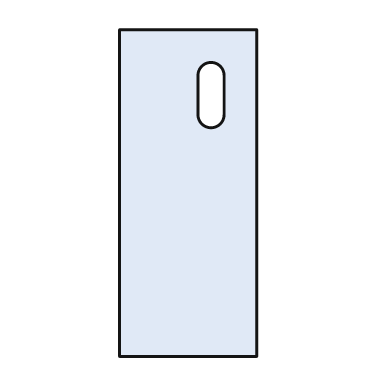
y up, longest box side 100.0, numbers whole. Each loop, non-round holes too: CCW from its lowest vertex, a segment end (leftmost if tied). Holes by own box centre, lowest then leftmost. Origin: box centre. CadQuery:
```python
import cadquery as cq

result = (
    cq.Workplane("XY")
    .moveTo(-21.0, -50.0)
    .lineTo(21.0, -50.0)
    .lineTo(21.0, 50.0)
    .lineTo(-21.0, 50.0)
    .close()
    .moveTo(3.0, 24.0)
    .threePointArc((7.0, 20.0), (11.0, 24.0))
    .lineTo(11.0, 36.0)
    .threePointArc((7.0, 40.0), (3.0, 36.0))
    .close()
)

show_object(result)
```